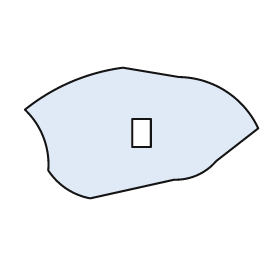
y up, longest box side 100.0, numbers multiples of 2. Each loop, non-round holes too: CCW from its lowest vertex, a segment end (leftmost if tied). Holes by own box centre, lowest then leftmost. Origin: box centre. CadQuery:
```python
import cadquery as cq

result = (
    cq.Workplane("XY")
    .moveTo(-22.0, -28.0)
    .lineTo(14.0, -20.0)
    .threePointArc((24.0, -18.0), (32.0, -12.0))
    .lineTo(50.0, 2.0)
    .threePointArc((36.0, 18.0), (16.0, 24.0))
    .lineTo(-8.0, 28.0)
    .threePointArc((-30.0, 22.0), (-50.0, 10.0))
    .threePointArc((-42.0, -2.0), (-40.0, -16.0))
    .threePointArc((-32.0, -24.0), (-22.0, -28.0))
    .close()
    .moveTo(-4.0, -6.0)
    .lineTo(4.0, -6.0)
    .lineTo(4.0, 6.0)
    .lineTo(-4.0, 6.0)
    .close()
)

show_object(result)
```